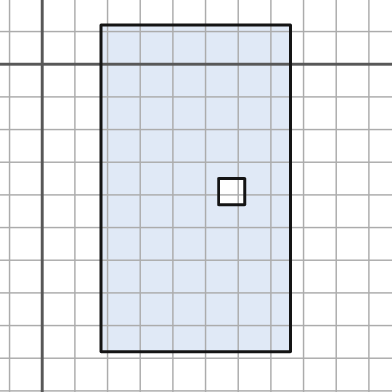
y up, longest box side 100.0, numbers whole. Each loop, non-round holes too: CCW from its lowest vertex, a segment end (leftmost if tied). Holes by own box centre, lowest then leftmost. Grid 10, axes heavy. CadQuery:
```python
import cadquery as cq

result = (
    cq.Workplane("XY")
    .moveTo(18.0, -88.0)
    .lineTo(76.0, -88.0)
    .lineTo(76.0, 12.0)
    .lineTo(18.0, 12.0)
    .close()
    .moveTo(54.0, -43.0)
    .lineTo(62.0, -43.0)
    .lineTo(62.0, -35.0)
    .lineTo(54.0, -35.0)
    .close()
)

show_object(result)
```